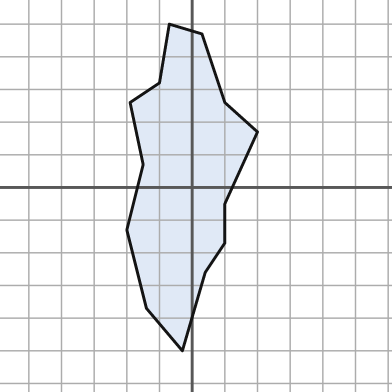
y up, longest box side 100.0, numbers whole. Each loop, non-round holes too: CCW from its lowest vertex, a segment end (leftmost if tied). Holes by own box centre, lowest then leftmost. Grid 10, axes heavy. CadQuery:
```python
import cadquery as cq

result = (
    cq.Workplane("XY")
    .moveTo(-3.0, -50.0)
    .lineTo(4.0, -26.0)
    .lineTo(10.0, -17.0)
    .lineTo(10.0, -5.0)
    .lineTo(20.0, 17.0)
    .lineTo(10.0, 26.0)
    .lineTo(3.0, 47.0)
    .lineTo(-7.0, 50.0)
    .lineTo(-10.0, 32.0)
    .lineTo(-19.0, 26.0)
    .lineTo(-15.0, 7.0)
    .lineTo(-20.0, -13.0)
    .lineTo(-14.0, -37.0)
    .close()
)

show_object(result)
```